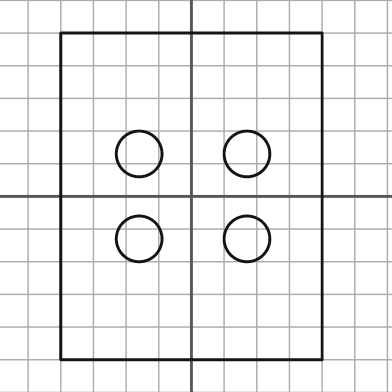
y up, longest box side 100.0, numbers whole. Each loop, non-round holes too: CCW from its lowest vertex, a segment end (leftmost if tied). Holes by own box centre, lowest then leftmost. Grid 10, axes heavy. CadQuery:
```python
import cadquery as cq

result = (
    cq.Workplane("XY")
    .moveTo(-40.0, -50.0)
    .lineTo(40.0, -50.0)
    .lineTo(40.0, 50.0)
    .lineTo(-40.0, 50.0)
    .close()
    .moveTo(-16.0, -13.0)
    .circle(7.0)
    .moveTo(17.0, -13.0)
    .circle(7.0)
    .moveTo(-16.0, 13.0)
    .circle(7.0)
    .moveTo(17.0, 13.0)
    .circle(7.0)
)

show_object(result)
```